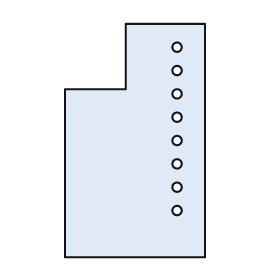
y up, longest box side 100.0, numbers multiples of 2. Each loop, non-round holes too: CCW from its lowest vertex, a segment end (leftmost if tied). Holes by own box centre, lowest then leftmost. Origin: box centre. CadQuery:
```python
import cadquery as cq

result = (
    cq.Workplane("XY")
    .moveTo(-30.0, -50.0)
    .lineTo(30.0, -50.0)
    .lineTo(30.0, 50.0)
    .lineTo(-4.0, 50.0)
    .lineTo(-4.0, 22.0)
    .lineTo(-30.0, 22.0)
    .close()
    .moveTo(18.0, -30.0)
    .circle(2.0)
    .moveTo(18.0, -20.0)
    .circle(2.0)
    .moveTo(18.0, -10.0)
    .circle(2.0)
    .moveTo(18.0, 0.0)
    .circle(2.0)
    .moveTo(18.0, 10.0)
    .circle(2.0)
    .moveTo(18.0, 20.0)
    .circle(2.0)
    .moveTo(18.0, 30.0)
    .circle(2.0)
    .moveTo(18.0, 40.0)
    .circle(2.0)
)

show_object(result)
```